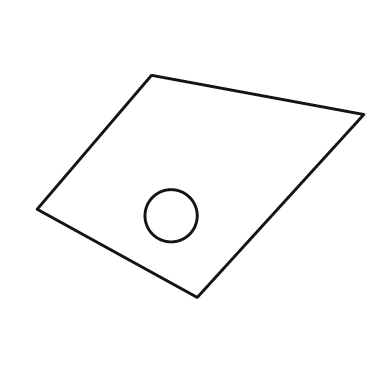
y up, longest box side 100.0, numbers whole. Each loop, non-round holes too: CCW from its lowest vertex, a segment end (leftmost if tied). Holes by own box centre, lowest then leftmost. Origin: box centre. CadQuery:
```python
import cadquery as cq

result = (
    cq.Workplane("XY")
    .moveTo(-1.0, -34.0)
    .lineTo(50.0, 22.0)
    .lineTo(-15.0, 34.0)
    .lineTo(-50.0, -7.0)
    .close()
    .moveTo(-9.0, -9.0)
    .circle(8.0)
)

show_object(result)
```